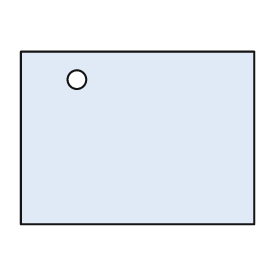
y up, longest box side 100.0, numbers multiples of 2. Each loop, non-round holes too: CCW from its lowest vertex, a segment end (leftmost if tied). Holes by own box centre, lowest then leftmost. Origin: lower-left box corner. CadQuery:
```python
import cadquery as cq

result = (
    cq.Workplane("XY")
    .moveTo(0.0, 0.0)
    .lineTo(100.0, 0.0)
    .lineTo(100.0, 74.0)
    .lineTo(0.0, 74.0)
    .close()
    .moveTo(24.0, 62.0)
    .circle(4.0)
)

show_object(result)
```